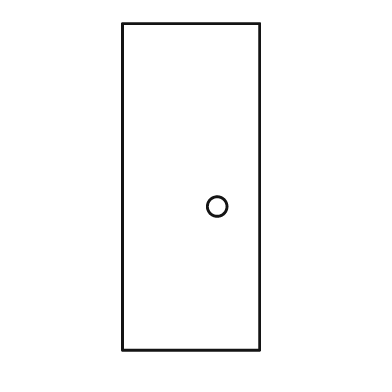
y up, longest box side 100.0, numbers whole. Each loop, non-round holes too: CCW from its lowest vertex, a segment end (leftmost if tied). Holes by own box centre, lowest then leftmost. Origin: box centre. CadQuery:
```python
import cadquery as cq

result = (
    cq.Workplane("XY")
    .moveTo(-21.0, -50.0)
    .lineTo(21.0, -50.0)
    .lineTo(21.0, 50.0)
    .lineTo(-21.0, 50.0)
    .close()
    .moveTo(8.0, -6.0)
    .circle(3.0)
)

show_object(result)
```